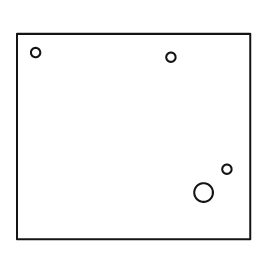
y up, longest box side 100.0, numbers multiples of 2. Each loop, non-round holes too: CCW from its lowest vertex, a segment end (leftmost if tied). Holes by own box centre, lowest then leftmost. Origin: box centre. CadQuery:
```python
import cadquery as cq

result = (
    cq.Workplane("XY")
    .moveTo(-50.0, -44.0)
    .lineTo(50.0, -44.0)
    .lineTo(50.0, 44.0)
    .lineTo(-50.0, 44.0)
    .close()
    .moveTo(30.0, -24.0)
    .circle(4.0)
    .moveTo(40.0, -14.0)
    .circle(2.0)
    .moveTo(16.0, 34.0)
    .circle(2.0)
    .moveTo(-42.0, 36.0)
    .circle(2.0)
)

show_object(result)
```